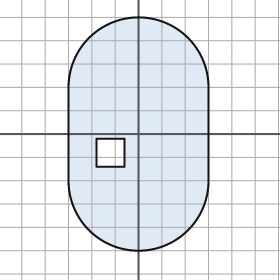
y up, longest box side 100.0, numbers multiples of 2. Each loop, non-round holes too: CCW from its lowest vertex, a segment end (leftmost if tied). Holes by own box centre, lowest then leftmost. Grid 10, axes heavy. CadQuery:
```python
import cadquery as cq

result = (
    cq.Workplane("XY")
    .moveTo(-30.0, -20.0)
    .threePointArc((0.0, -50.0), (30.0, -20.0))
    .lineTo(30.0, 20.0)
    .threePointArc((0.0, 50.0), (-30.0, 20.0))
    .close()
    .moveTo(-18.0, -14.0)
    .lineTo(-6.0, -14.0)
    .lineTo(-6.0, -2.0)
    .lineTo(-18.0, -2.0)
    .close()
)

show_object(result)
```